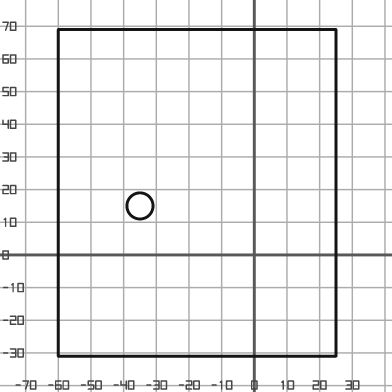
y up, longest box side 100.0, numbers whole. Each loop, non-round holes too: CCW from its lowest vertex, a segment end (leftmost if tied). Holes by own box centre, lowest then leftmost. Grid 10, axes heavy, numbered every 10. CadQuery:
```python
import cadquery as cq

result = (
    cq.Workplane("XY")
    .moveTo(-60.0, -31.0)
    .lineTo(25.0, -31.0)
    .lineTo(25.0, 69.0)
    .lineTo(-60.0, 69.0)
    .close()
    .moveTo(-35.0, 15.0)
    .circle(4.0)
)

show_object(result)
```